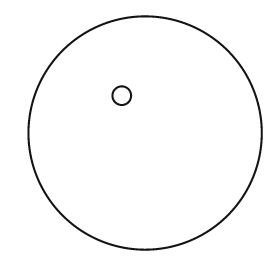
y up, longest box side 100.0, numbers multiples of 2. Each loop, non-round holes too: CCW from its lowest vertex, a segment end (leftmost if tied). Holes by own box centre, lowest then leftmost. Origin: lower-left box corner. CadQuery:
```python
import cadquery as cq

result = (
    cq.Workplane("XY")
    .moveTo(50.0, 50.0)
    .circle(50.0)
    .moveTo(40.0, 66.0)
    .circle(4.0)
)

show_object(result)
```